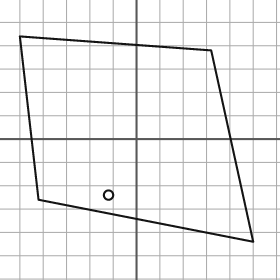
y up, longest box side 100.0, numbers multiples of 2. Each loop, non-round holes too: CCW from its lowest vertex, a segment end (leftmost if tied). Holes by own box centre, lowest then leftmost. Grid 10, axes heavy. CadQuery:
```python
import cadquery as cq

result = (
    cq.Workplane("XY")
    .moveTo(50.0, -44.0)
    .lineTo(32.0, 38.0)
    .lineTo(-50.0, 44.0)
    .lineTo(-42.0, -26.0)
    .close()
    .moveTo(-12.0, -24.0)
    .circle(2.0)
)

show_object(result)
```